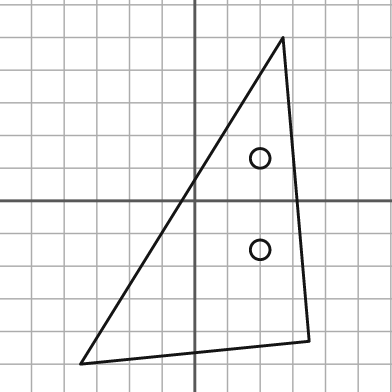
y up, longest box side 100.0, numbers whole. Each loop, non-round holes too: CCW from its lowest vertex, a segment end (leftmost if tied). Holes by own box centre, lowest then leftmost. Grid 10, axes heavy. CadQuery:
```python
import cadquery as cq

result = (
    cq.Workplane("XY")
    .moveTo(-35.0, -50.0)
    .lineTo(35.0, -43.0)
    .lineTo(27.0, 50.0)
    .close()
    .moveTo(20.0, -15.0)
    .circle(3.0)
    .moveTo(20.0, 13.0)
    .circle(3.0)
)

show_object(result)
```